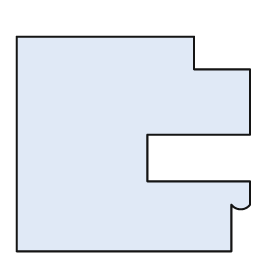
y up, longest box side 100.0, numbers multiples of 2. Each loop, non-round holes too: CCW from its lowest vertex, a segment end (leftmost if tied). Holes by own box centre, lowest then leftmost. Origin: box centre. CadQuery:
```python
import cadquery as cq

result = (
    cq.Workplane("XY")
    .moveTo(-50.0, -46.0)
    .lineTo(42.0, -46.0)
    .lineTo(42.0, -26.0)
    .threePointArc((46.0, -28.0), (50.0, -26.0))
    .lineTo(50.0, -16.0)
    .lineTo(6.0, -16.0)
    .lineTo(6.0, 4.0)
    .lineTo(50.0, 4.0)
    .lineTo(50.0, 32.0)
    .lineTo(26.0, 32.0)
    .lineTo(26.0, 46.0)
    .lineTo(-50.0, 46.0)
    .close()
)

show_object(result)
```